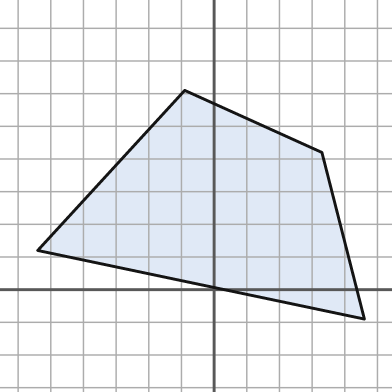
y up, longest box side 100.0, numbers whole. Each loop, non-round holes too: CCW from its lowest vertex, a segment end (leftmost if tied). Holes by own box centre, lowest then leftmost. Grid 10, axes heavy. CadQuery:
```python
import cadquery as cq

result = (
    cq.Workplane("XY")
    .moveTo(46.0, -9.0)
    .lineTo(33.0, 42.0)
    .lineTo(-9.0, 61.0)
    .lineTo(-54.0, 12.0)
    .close()
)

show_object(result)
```